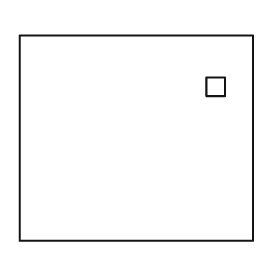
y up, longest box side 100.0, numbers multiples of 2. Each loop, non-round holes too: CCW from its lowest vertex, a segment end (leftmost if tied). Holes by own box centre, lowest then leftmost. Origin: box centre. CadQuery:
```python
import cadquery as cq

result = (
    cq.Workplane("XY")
    .moveTo(-50.0, -44.0)
    .lineTo(50.0, -44.0)
    .lineTo(50.0, 44.0)
    .lineTo(-50.0, 44.0)
    .close()
    .moveTo(30.0, 18.0)
    .lineTo(38.0, 18.0)
    .lineTo(38.0, 26.0)
    .lineTo(30.0, 26.0)
    .close()
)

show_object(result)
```